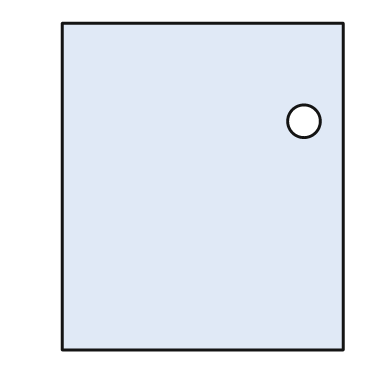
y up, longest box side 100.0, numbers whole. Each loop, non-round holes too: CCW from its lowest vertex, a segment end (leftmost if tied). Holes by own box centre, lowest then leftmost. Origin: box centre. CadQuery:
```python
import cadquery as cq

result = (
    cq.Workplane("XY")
    .moveTo(-43.0, -50.0)
    .lineTo(43.0, -50.0)
    .lineTo(43.0, 50.0)
    .lineTo(-43.0, 50.0)
    .close()
    .moveTo(31.0, 20.0)
    .circle(5.0)
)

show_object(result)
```